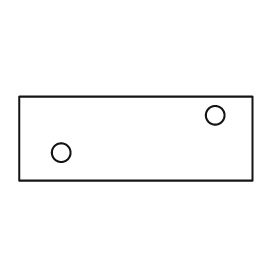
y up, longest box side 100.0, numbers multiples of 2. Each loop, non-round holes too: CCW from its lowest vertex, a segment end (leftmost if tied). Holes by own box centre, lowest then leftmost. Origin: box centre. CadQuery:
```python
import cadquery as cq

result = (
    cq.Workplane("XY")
    .moveTo(-50.0, -18.0)
    .lineTo(50.0, -18.0)
    .lineTo(50.0, 18.0)
    .lineTo(-50.0, 18.0)
    .close()
    .moveTo(-32.0, -6.0)
    .circle(4.0)
    .moveTo(34.0, 10.0)
    .circle(4.0)
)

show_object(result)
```